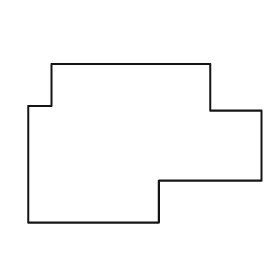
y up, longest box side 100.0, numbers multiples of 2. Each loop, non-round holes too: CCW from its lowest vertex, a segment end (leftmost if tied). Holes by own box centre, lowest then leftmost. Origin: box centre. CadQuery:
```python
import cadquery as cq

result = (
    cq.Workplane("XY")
    .moveTo(-50.0, -34.0)
    .lineTo(6.0, -34.0)
    .lineTo(6.0, -16.0)
    .lineTo(50.0, -16.0)
    .lineTo(50.0, 14.0)
    .lineTo(28.0, 14.0)
    .lineTo(28.0, 34.0)
    .lineTo(-40.0, 34.0)
    .lineTo(-40.0, 16.0)
    .lineTo(-50.0, 16.0)
    .close()
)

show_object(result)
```